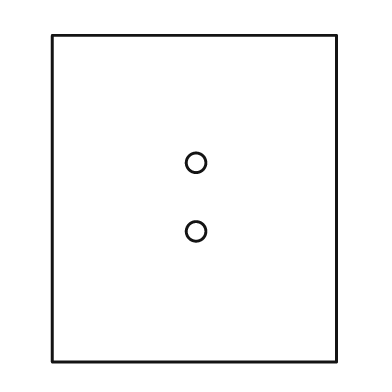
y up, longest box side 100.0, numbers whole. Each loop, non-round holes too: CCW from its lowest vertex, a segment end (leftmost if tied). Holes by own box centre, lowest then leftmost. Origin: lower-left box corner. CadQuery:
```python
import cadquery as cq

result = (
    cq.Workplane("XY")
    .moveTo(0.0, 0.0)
    .lineTo(87.0, 0.0)
    .lineTo(87.0, 100.0)
    .lineTo(0.0, 100.0)
    .close()
    .moveTo(44.0, 40.0)
    .circle(3.0)
    .moveTo(44.0, 61.0)
    .circle(3.0)
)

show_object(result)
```